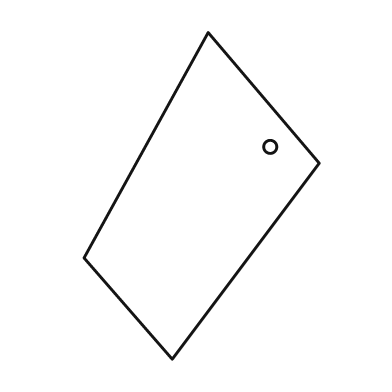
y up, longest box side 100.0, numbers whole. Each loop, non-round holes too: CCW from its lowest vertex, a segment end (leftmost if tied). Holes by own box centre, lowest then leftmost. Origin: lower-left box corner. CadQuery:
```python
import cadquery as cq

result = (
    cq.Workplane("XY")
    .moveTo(27.0, 0.0)
    .lineTo(72.0, 60.0)
    .lineTo(38.0, 100.0)
    .lineTo(0.0, 31.0)
    .close()
    .moveTo(57.0, 65.0)
    .circle(2.0)
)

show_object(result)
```